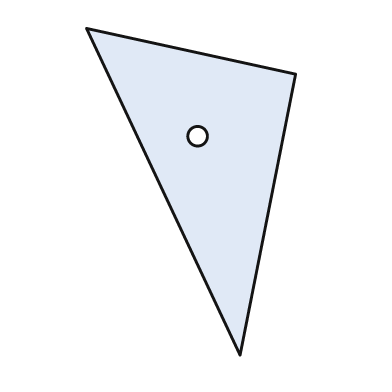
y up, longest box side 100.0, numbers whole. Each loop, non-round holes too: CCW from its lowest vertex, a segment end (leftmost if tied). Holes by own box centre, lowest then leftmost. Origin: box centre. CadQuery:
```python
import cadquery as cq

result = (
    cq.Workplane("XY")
    .moveTo(15.0, -50.0)
    .lineTo(32.0, 36.0)
    .lineTo(-32.0, 50.0)
    .close()
    .moveTo(2.0, 17.0)
    .circle(3.0)
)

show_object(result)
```